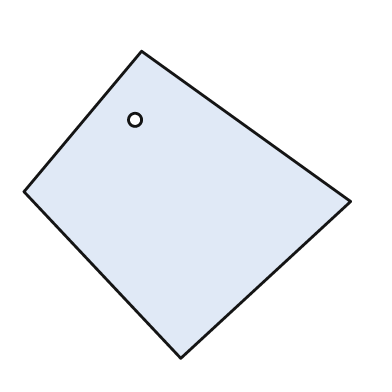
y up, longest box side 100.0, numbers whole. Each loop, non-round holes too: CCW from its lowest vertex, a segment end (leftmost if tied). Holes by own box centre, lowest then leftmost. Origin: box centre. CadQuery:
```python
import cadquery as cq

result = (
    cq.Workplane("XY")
    .moveTo(-2.0, -47.0)
    .lineTo(50.0, 1.0)
    .lineTo(-14.0, 47.0)
    .lineTo(-50.0, 4.0)
    .close()
    .moveTo(-16.0, 26.0)
    .circle(2.0)
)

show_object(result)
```